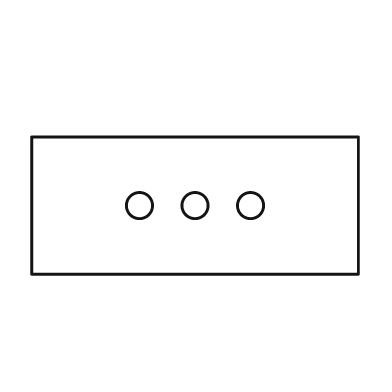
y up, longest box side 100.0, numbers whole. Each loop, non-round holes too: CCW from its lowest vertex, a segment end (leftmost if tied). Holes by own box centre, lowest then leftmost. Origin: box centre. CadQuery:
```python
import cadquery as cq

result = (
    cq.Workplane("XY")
    .moveTo(-50.0, -21.0)
    .lineTo(50.0, -21.0)
    .lineTo(50.0, 21.0)
    .lineTo(-50.0, 21.0)
    .close()
    .moveTo(-17.0, 0.0)
    .circle(4.0)
    .moveTo(0.0, 0.0)
    .circle(4.0)
    .moveTo(17.0, 0.0)
    .circle(4.0)
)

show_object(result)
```